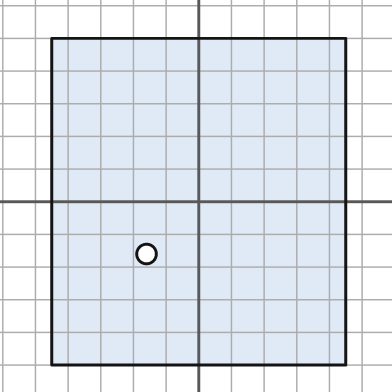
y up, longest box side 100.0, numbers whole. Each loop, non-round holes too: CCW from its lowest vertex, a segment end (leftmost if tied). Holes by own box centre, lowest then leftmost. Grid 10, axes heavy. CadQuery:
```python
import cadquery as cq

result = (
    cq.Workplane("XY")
    .moveTo(-45.0, -50.0)
    .lineTo(45.0, -50.0)
    .lineTo(45.0, 50.0)
    .lineTo(-45.0, 50.0)
    .close()
    .moveTo(-16.0, -16.0)
    .circle(3.0)
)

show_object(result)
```